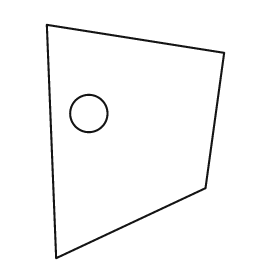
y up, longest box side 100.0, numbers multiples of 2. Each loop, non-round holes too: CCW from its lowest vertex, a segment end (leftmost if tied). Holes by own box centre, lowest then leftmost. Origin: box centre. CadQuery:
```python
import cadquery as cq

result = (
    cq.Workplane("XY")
    .moveTo(-34.0, -50.0)
    .lineTo(30.0, -20.0)
    .lineTo(38.0, 38.0)
    .lineTo(-38.0, 50.0)
    .close()
    .moveTo(-20.0, 12.0)
    .circle(8.0)
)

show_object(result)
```